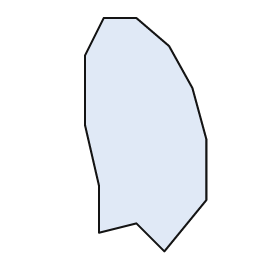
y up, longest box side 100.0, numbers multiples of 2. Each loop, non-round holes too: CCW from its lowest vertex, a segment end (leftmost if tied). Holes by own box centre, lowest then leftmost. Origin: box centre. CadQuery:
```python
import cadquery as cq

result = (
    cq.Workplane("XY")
    .moveTo(8.0, -50.0)
    .lineTo(26.0, -28.0)
    .lineTo(26.0, -2.0)
    .lineTo(20.0, 20.0)
    .lineTo(10.0, 38.0)
    .lineTo(-4.0, 50.0)
    .lineTo(-18.0, 50.0)
    .lineTo(-26.0, 34.0)
    .lineTo(-26.0, 4.0)
    .lineTo(-20.0, -22.0)
    .lineTo(-20.0, -42.0)
    .lineTo(-4.0, -38.0)
    .close()
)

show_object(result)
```